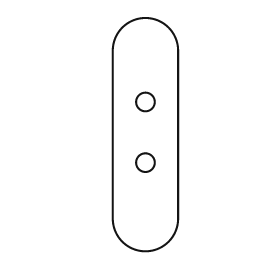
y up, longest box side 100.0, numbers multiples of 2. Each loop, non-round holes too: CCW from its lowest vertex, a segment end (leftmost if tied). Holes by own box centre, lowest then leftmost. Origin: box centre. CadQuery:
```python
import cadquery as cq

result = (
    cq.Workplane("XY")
    .moveTo(-14.0, -36.0)
    .threePointArc((0.0, -50.0), (14.0, -36.0))
    .lineTo(14.0, 36.0)
    .threePointArc((0.0, 50.0), (-14.0, 36.0))
    .close()
    .moveTo(0.0, -12.0)
    .circle(4.0)
    .moveTo(0.0, 14.0)
    .circle(4.0)
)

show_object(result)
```